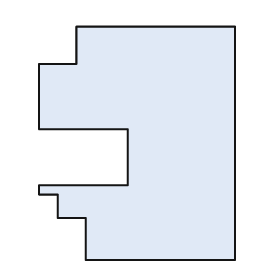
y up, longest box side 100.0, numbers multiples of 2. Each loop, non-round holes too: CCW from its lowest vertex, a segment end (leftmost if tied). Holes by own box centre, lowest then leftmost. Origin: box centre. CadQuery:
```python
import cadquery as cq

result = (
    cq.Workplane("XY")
    .moveTo(-22.0, -50.0)
    .lineTo(42.0, -50.0)
    .lineTo(42.0, 50.0)
    .lineTo(-26.0, 50.0)
    .lineTo(-26.0, 34.0)
    .lineTo(-42.0, 34.0)
    .lineTo(-42.0, 6.0)
    .lineTo(-4.0, 6.0)
    .lineTo(-4.0, -18.0)
    .lineTo(-42.0, -18.0)
    .lineTo(-42.0, -22.0)
    .lineTo(-34.0, -22.0)
    .lineTo(-34.0, -32.0)
    .lineTo(-22.0, -32.0)
    .close()
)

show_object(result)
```